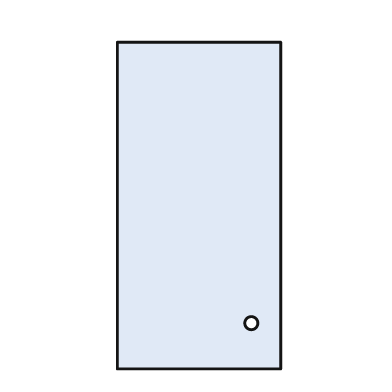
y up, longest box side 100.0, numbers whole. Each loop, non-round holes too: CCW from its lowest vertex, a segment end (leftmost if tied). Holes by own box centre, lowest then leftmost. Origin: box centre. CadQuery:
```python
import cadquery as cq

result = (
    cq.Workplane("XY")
    .moveTo(-25.0, -50.0)
    .lineTo(25.0, -50.0)
    .lineTo(25.0, 50.0)
    .lineTo(-25.0, 50.0)
    .close()
    .moveTo(16.0, -36.0)
    .circle(2.0)
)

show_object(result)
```